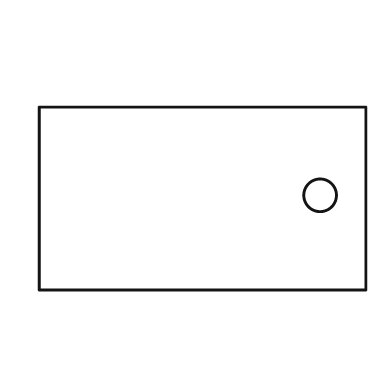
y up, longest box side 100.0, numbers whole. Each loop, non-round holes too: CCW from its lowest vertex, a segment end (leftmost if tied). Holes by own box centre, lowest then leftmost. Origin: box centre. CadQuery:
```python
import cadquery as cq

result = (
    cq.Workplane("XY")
    .moveTo(-50.0, -28.0)
    .lineTo(50.0, -28.0)
    .lineTo(50.0, 28.0)
    .lineTo(-50.0, 28.0)
    .close()
    .moveTo(36.0, 1.0)
    .circle(5.0)
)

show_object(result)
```